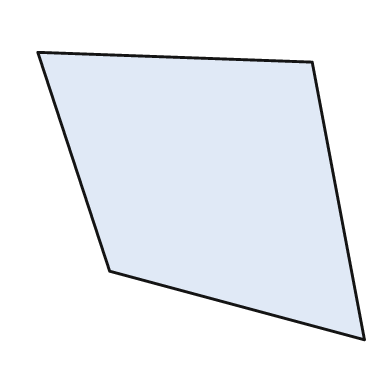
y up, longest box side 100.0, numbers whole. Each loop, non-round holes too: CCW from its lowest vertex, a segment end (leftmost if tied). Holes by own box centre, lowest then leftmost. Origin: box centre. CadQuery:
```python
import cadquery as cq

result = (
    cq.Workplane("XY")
    .moveTo(50.0, -44.0)
    .lineTo(34.0, 41.0)
    .lineTo(-50.0, 44.0)
    .lineTo(-28.0, -23.0)
    .close()
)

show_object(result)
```